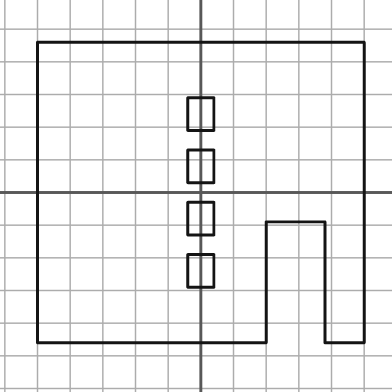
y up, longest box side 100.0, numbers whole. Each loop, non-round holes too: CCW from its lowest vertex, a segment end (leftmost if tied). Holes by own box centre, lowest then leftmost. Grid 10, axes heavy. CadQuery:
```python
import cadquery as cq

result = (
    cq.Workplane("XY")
    .moveTo(-50.0, -46.0)
    .lineTo(20.0, -46.0)
    .lineTo(20.0, -9.0)
    .lineTo(38.0, -9.0)
    .lineTo(38.0, -46.0)
    .lineTo(50.0, -46.0)
    .lineTo(50.0, 46.0)
    .lineTo(-50.0, 46.0)
    .close()
    .moveTo(-4.0, -29.0)
    .lineTo(4.0, -29.0)
    .lineTo(4.0, -19.0)
    .lineTo(-4.0, -19.0)
    .close()
    .moveTo(-4.0, -13.0)
    .lineTo(4.0, -13.0)
    .lineTo(4.0, -3.0)
    .lineTo(-4.0, -3.0)
    .close()
    .moveTo(-4.0, 3.0)
    .lineTo(4.0, 3.0)
    .lineTo(4.0, 13.0)
    .lineTo(-4.0, 13.0)
    .close()
    .moveTo(-4.0, 19.0)
    .lineTo(4.0, 19.0)
    .lineTo(4.0, 29.0)
    .lineTo(-4.0, 29.0)
    .close()
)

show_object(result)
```